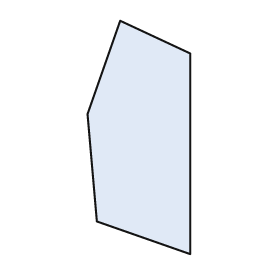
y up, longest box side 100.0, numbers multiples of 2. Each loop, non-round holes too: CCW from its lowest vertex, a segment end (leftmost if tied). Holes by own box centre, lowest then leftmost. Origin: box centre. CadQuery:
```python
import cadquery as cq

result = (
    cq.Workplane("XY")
    .moveTo(22.0, -50.0)
    .lineTo(22.0, 36.0)
    .lineTo(-8.0, 50.0)
    .lineTo(-22.0, 10.0)
    .lineTo(-18.0, -36.0)
    .close()
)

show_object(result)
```